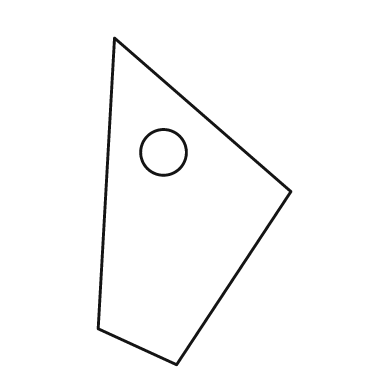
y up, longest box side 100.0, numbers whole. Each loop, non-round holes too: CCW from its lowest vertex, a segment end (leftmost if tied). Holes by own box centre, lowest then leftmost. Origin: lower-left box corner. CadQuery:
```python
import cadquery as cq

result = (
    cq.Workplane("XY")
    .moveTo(24.0, 0.0)
    .lineTo(59.0, 53.0)
    .lineTo(5.0, 100.0)
    .lineTo(0.0, 11.0)
    .close()
    .moveTo(20.0, 65.0)
    .circle(7.0)
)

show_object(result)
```